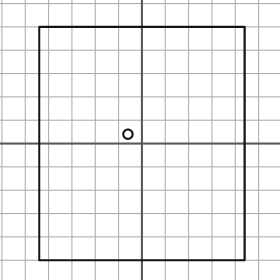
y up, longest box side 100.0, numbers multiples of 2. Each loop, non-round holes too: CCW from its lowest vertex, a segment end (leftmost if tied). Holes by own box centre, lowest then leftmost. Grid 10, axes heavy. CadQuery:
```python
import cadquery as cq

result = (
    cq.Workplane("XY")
    .moveTo(-44.0, -50.0)
    .lineTo(44.0, -50.0)
    .lineTo(44.0, 50.0)
    .lineTo(-44.0, 50.0)
    .close()
    .moveTo(-6.0, 4.0)
    .circle(2.0)
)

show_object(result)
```